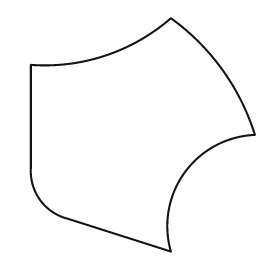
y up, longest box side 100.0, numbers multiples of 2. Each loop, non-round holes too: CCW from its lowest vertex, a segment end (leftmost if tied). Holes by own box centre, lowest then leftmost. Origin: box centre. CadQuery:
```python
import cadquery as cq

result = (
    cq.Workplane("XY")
    .moveTo(12.0, -50.0)
    .threePointArc((18.0, -16.0), (48.0, 0.0))
    .threePointArc((34.0, 28.0), (12.0, 50.0))
    .threePointArc((-16.0, 34.0), (-48.0, 30.0))
    .lineTo(-48.0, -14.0)
    .threePointArc((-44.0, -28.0), (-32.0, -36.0))
    .close()
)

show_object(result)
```